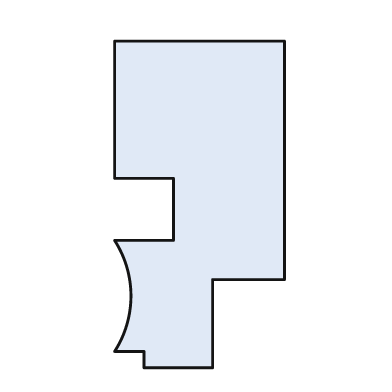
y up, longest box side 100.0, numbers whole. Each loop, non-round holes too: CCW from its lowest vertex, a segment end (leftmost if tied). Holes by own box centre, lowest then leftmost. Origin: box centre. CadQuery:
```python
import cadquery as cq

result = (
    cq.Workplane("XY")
    .moveTo(-17.0, -50.0)
    .lineTo(4.0, -50.0)
    .lineTo(4.0, -23.0)
    .lineTo(26.0, -23.0)
    .lineTo(26.0, 50.0)
    .lineTo(-26.0, 50.0)
    .lineTo(-26.0, 8.0)
    .lineTo(-8.0, 8.0)
    .lineTo(-8.0, -11.0)
    .lineTo(-26.0, -11.0)
    .threePointArc((-21.0, -28.0), (-26.0, -45.0))
    .lineTo(-17.0, -45.0)
    .close()
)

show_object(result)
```